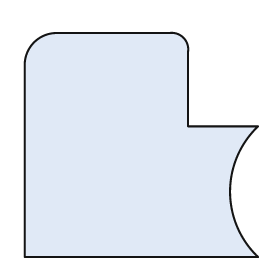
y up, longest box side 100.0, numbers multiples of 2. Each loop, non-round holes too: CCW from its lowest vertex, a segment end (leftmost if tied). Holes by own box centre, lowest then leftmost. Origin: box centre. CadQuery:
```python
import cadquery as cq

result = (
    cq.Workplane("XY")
    .moveTo(-50.0, -48.0)
    .lineTo(50.0, -48.0)
    .threePointArc((38.0, -20.0), (50.0, 8.0))
    .lineTo(20.0, 8.0)
    .lineTo(20.0, 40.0)
    .threePointArc((18.0, 46.0), (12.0, 48.0))
    .lineTo(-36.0, 48.0)
    .threePointArc((-46.0, 44.0), (-50.0, 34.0))
    .close()
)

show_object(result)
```